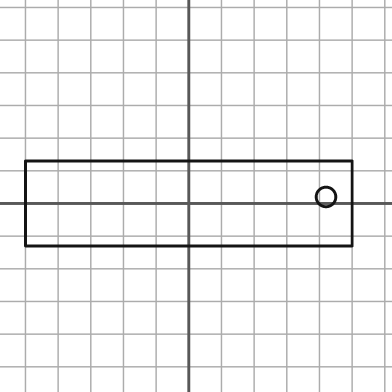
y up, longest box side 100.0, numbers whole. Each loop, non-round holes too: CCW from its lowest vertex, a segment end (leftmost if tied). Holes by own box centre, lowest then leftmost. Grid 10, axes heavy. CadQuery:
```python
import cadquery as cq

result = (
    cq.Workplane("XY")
    .moveTo(-50.0, -13.0)
    .lineTo(50.0, -13.0)
    .lineTo(50.0, 13.0)
    .lineTo(-50.0, 13.0)
    .close()
    .moveTo(42.0, 2.0)
    .circle(3.0)
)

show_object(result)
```